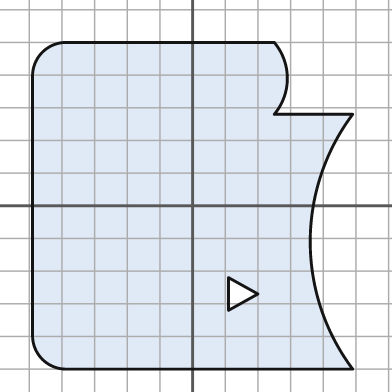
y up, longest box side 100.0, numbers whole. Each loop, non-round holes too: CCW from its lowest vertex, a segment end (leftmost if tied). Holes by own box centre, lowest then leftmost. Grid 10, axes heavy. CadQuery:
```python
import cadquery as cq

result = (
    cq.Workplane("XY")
    .moveTo(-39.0, -50.0)
    .lineTo(49.0, -50.0)
    .threePointArc((36.0, -11.0), (49.0, 28.0))
    .lineTo(25.0, 28.0)
    .threePointArc((29.0, 39.0), (25.0, 50.0))
    .lineTo(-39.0, 50.0)
    .threePointArc((-46.0, 47.0), (-49.0, 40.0))
    .lineTo(-49.0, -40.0)
    .threePointArc((-46.0, -47.0), (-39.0, -50.0))
    .close()
    .moveTo(11.0, -32.0)
    .lineTo(20.0, -27.0)
    .lineTo(11.0, -22.0)
    .close()
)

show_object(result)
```